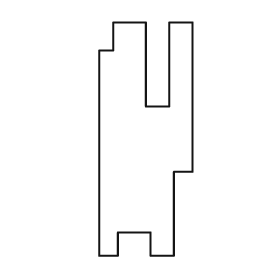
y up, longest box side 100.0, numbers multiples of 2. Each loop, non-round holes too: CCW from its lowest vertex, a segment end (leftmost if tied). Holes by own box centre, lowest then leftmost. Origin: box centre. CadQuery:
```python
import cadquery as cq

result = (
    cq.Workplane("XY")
    .moveTo(-20.0, -50.0)
    .lineTo(-12.0, -50.0)
    .lineTo(-12.0, -40.0)
    .lineTo(2.0, -40.0)
    .lineTo(2.0, -50.0)
    .lineTo(12.0, -50.0)
    .lineTo(12.0, -14.0)
    .lineTo(20.0, -14.0)
    .lineTo(20.0, 50.0)
    .lineTo(10.0, 50.0)
    .lineTo(10.0, 14.0)
    .lineTo(0.0, 14.0)
    .lineTo(0.0, 50.0)
    .lineTo(-14.0, 50.0)
    .lineTo(-14.0, 38.0)
    .lineTo(-20.0, 38.0)
    .close()
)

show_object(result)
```